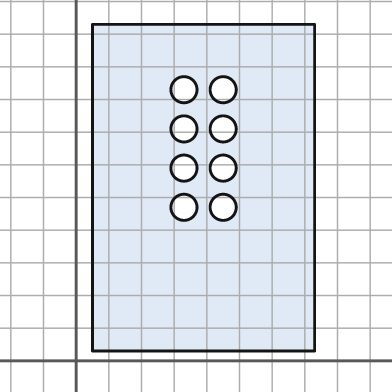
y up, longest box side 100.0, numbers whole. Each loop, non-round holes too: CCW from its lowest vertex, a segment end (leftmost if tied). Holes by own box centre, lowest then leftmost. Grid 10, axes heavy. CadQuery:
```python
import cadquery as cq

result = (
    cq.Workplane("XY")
    .moveTo(5.0, 3.0)
    .lineTo(73.0, 3.0)
    .lineTo(73.0, 103.0)
    .lineTo(5.0, 103.0)
    .close()
    .moveTo(33.0, 47.0)
    .circle(4.0)
    .moveTo(45.0, 47.0)
    .circle(4.0)
    .moveTo(33.0, 59.0)
    .circle(4.0)
    .moveTo(45.0, 59.0)
    .circle(4.0)
    .moveTo(33.0, 71.0)
    .circle(4.0)
    .moveTo(45.0, 71.0)
    .circle(4.0)
    .moveTo(33.0, 83.0)
    .circle(4.0)
    .moveTo(45.0, 83.0)
    .circle(4.0)
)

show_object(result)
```